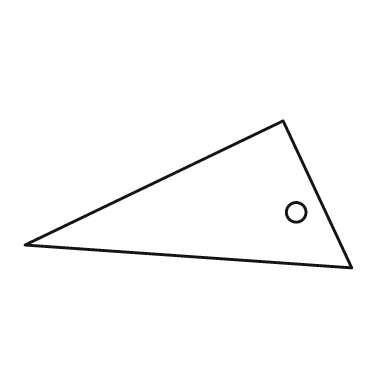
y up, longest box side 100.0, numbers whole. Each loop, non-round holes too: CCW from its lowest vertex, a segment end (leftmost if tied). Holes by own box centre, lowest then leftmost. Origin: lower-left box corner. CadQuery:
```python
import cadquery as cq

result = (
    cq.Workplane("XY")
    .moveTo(100.0, 0.0)
    .lineTo(79.0, 45.0)
    .lineTo(0.0, 7.0)
    .close()
    .moveTo(83.0, 17.0)
    .circle(3.0)
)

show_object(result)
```